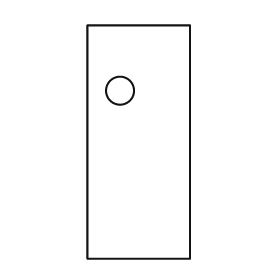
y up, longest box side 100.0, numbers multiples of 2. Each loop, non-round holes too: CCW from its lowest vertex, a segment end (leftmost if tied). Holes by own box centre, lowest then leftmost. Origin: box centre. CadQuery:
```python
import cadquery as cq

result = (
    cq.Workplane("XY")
    .moveTo(-22.0, -50.0)
    .lineTo(22.0, -50.0)
    .lineTo(22.0, 50.0)
    .lineTo(-22.0, 50.0)
    .close()
    .moveTo(-8.0, 22.0)
    .circle(6.0)
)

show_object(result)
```